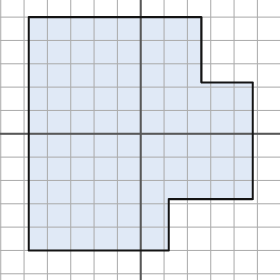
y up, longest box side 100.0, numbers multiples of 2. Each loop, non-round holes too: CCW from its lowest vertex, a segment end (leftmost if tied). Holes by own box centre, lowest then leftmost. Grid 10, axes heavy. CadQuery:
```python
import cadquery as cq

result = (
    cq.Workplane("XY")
    .moveTo(-48.0, -50.0)
    .lineTo(12.0, -50.0)
    .lineTo(12.0, -28.0)
    .lineTo(48.0, -28.0)
    .lineTo(48.0, 22.0)
    .lineTo(26.0, 22.0)
    .lineTo(26.0, 50.0)
    .lineTo(-48.0, 50.0)
    .close()
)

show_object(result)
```